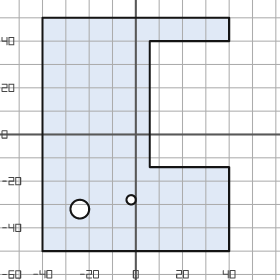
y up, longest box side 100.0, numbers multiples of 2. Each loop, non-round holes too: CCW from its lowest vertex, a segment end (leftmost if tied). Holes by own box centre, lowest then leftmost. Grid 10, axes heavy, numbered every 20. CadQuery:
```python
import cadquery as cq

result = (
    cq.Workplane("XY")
    .moveTo(-40.0, -50.0)
    .lineTo(40.0, -50.0)
    .lineTo(40.0, -14.0)
    .lineTo(6.0, -14.0)
    .lineTo(6.0, 40.0)
    .lineTo(40.0, 40.0)
    .lineTo(40.0, 50.0)
    .lineTo(-40.0, 50.0)
    .close()
    .moveTo(-24.0, -32.0)
    .circle(4.0)
    .moveTo(-2.0, -28.0)
    .circle(2.0)
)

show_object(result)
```